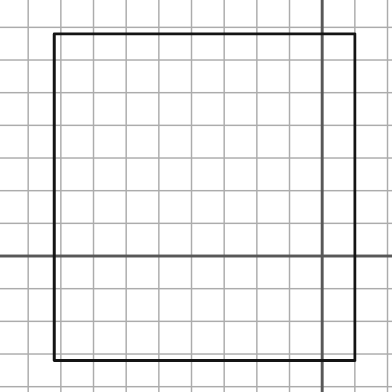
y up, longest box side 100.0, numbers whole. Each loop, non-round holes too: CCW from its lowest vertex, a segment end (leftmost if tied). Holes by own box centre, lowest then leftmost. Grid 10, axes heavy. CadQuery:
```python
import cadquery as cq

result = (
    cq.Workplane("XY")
    .moveTo(-82.0, -32.0)
    .lineTo(10.0, -32.0)
    .lineTo(10.0, 68.0)
    .lineTo(-82.0, 68.0)
    .close()
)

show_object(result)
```